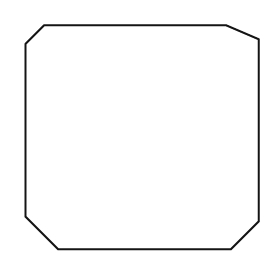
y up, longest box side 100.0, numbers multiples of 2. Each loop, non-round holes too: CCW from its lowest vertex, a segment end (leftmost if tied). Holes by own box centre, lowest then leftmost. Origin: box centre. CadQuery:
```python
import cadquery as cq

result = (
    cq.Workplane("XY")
    .moveTo(-36.0, -48.0)
    .lineTo(38.0, -48.0)
    .lineTo(50.0, -36.0)
    .lineTo(50.0, 42.0)
    .lineTo(36.0, 48.0)
    .lineTo(-42.0, 48.0)
    .lineTo(-50.0, 40.0)
    .lineTo(-50.0, -34.0)
    .close()
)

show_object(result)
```